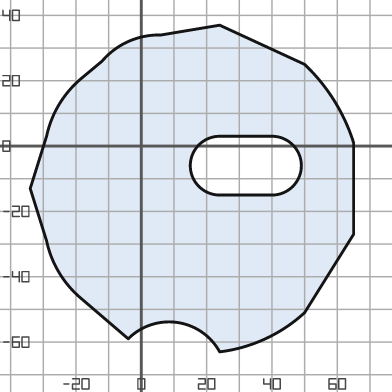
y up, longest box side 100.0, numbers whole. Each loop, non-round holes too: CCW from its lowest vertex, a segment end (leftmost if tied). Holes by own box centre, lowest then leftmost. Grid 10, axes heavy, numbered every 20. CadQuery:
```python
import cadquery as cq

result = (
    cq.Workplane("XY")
    .moveTo(24.0, -63.0)
    .threePointArc((38.0, -59.0), (50.0, -51.0))
    .lineTo(65.0, -27.0)
    .lineTo(65.0, 1.0)
    .threePointArc((59.0, 14.0), (50.0, 25.0))
    .lineTo(24.0, 37.0)
    .lineTo(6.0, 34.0)
    .threePointArc((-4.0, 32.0), (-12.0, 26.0))
    .lineTo(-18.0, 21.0)
    .threePointArc((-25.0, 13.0), (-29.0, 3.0))
    .lineTo(-34.0, -13.0)
    .lineTo(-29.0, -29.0)
    .threePointArc((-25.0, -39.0), (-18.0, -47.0))
    .lineTo(-4.0, -59.0)
    .threePointArc((11.0, -54.0), (24.0, -63.0))
    .close()
    .moveTo(24.0, -15.0)
    .lineTo(40.0, -15.0)
    .threePointArc((49.0, -6.0), (40.0, 3.0))
    .lineTo(24.0, 3.0)
    .threePointArc((15.0, -6.0), (24.0, -15.0))
    .close()
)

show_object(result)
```